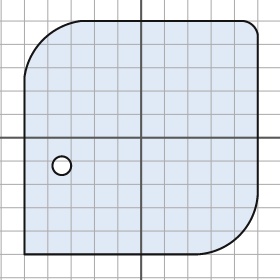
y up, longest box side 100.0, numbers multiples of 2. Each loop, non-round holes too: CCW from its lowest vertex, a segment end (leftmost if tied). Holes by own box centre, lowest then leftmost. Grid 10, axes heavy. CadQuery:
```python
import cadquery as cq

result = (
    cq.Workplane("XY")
    .moveTo(-50.0, -50.0)
    .lineTo(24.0, -50.0)
    .threePointArc((42.0, -42.0), (50.0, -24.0))
    .lineTo(50.0, 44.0)
    .threePointArc((48.0, 48.0), (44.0, 50.0))
    .lineTo(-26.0, 50.0)
    .threePointArc((-42.0, 42.0), (-50.0, 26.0))
    .close()
    .moveTo(-34.0, -12.0)
    .circle(4.0)
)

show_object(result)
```